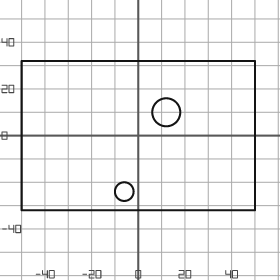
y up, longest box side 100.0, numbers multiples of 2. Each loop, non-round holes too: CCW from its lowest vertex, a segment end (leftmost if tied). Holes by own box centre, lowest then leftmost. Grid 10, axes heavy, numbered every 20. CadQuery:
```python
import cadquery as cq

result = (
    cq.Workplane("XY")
    .moveTo(-50.0, -32.0)
    .lineTo(50.0, -32.0)
    .lineTo(50.0, 32.0)
    .lineTo(-50.0, 32.0)
    .close()
    .moveTo(-6.0, -24.0)
    .circle(4.0)
    .moveTo(12.0, 10.0)
    .circle(6.0)
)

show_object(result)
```